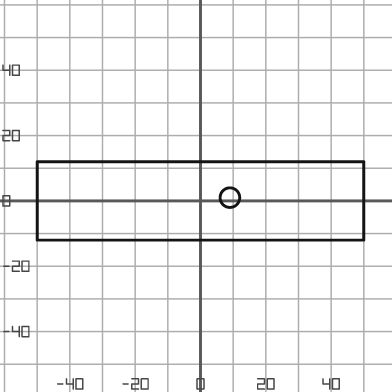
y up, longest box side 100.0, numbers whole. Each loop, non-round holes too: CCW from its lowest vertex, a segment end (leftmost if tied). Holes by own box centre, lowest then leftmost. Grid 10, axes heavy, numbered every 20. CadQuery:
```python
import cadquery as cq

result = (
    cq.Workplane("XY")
    .moveTo(-50.0, -12.0)
    .lineTo(50.0, -12.0)
    .lineTo(50.0, 12.0)
    .lineTo(-50.0, 12.0)
    .close()
    .moveTo(9.0, 1.0)
    .circle(3.0)
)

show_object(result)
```